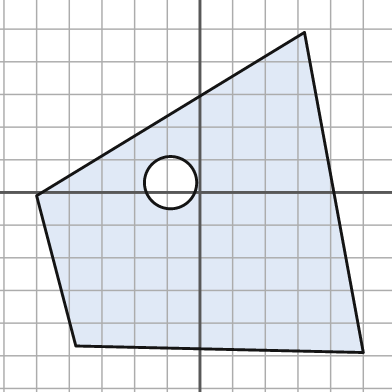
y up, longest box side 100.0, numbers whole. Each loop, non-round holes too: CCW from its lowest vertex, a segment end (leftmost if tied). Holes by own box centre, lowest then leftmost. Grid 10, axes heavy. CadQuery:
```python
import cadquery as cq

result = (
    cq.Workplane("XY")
    .moveTo(50.0, -49.0)
    .lineTo(32.0, 49.0)
    .lineTo(-50.0, -1.0)
    .lineTo(-38.0, -47.0)
    .close()
    .moveTo(-9.0, 3.0)
    .circle(8.0)
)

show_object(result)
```